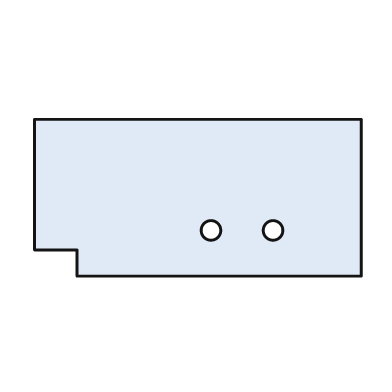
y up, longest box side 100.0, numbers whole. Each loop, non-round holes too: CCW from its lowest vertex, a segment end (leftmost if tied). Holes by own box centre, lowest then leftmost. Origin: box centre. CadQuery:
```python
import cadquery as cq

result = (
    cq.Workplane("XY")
    .moveTo(-37.0, -24.0)
    .lineTo(50.0, -24.0)
    .lineTo(50.0, 24.0)
    .lineTo(-50.0, 24.0)
    .lineTo(-50.0, -16.0)
    .lineTo(-37.0, -16.0)
    .close()
    .moveTo(4.0, -10.0)
    .circle(3.0)
    .moveTo(23.0, -10.0)
    .circle(3.0)
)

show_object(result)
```